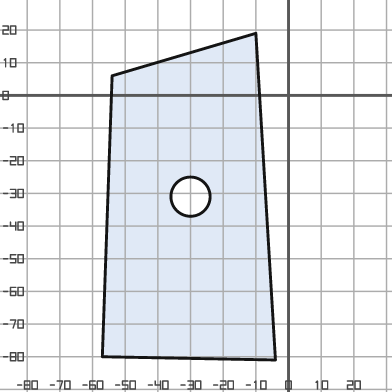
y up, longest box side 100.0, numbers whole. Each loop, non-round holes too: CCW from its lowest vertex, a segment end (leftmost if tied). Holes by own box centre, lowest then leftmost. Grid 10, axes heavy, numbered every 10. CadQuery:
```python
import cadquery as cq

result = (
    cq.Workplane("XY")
    .moveTo(-4.0, -81.0)
    .lineTo(-10.0, 19.0)
    .lineTo(-54.0, 6.0)
    .lineTo(-57.0, -80.0)
    .close()
    .moveTo(-30.0, -31.0)
    .circle(6.0)
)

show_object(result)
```